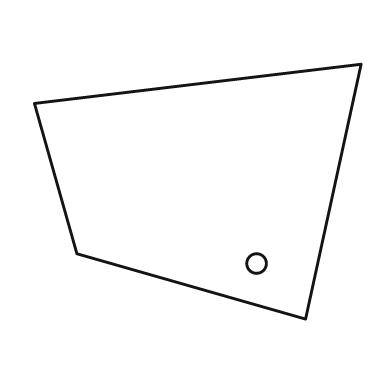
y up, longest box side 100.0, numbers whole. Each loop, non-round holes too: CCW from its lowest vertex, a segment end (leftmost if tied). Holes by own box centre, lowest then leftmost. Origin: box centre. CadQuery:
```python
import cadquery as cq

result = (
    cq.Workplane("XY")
    .moveTo(33.0, -39.0)
    .lineTo(50.0, 39.0)
    .lineTo(-50.0, 27.0)
    .lineTo(-37.0, -19.0)
    .close()
    .moveTo(18.0, -22.0)
    .circle(3.0)
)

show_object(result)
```